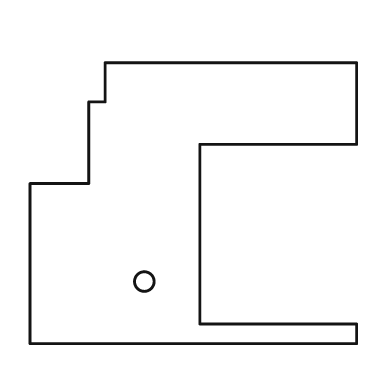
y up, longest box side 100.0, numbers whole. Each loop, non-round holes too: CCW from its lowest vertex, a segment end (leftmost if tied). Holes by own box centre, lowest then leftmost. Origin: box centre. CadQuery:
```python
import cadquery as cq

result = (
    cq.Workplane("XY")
    .moveTo(-50.0, -43.0)
    .lineTo(50.0, -43.0)
    .lineTo(50.0, -37.0)
    .lineTo(2.0, -37.0)
    .lineTo(2.0, 18.0)
    .lineTo(50.0, 18.0)
    .lineTo(50.0, 43.0)
    .lineTo(-27.0, 43.0)
    .lineTo(-27.0, 31.0)
    .lineTo(-32.0, 31.0)
    .lineTo(-32.0, 6.0)
    .lineTo(-50.0, 6.0)
    .close()
    .moveTo(-15.0, -24.0)
    .circle(3.0)
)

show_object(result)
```